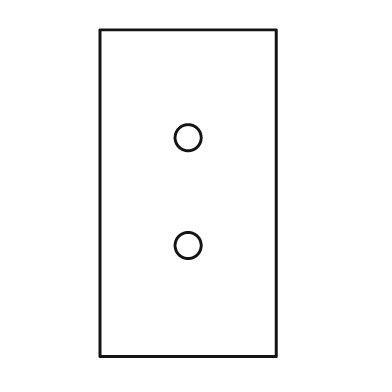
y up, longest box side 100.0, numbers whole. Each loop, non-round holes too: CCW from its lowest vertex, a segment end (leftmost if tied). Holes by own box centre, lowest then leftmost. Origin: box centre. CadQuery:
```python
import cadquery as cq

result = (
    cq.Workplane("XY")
    .moveTo(-27.0, -50.0)
    .lineTo(27.0, -50.0)
    .lineTo(27.0, 50.0)
    .lineTo(-27.0, 50.0)
    .close()
    .moveTo(0.0, -16.0)
    .circle(4.0)
    .moveTo(0.0, 17.0)
    .circle(4.0)
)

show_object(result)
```